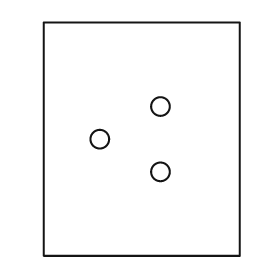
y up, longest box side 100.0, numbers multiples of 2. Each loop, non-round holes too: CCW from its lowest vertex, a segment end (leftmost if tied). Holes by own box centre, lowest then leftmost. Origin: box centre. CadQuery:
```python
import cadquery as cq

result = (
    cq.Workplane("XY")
    .moveTo(-42.0, -50.0)
    .lineTo(42.0, -50.0)
    .lineTo(42.0, 50.0)
    .lineTo(-42.0, 50.0)
    .close()
    .moveTo(8.0, -14.0)
    .circle(4.0)
    .moveTo(-18.0, 0.0)
    .circle(4.0)
    .moveTo(8.0, 14.0)
    .circle(4.0)
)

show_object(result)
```